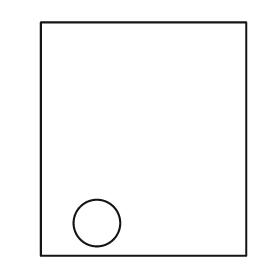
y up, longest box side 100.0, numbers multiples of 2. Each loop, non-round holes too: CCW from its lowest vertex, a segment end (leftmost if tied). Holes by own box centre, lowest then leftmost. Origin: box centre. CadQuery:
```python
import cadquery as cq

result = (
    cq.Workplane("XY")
    .moveTo(-44.0, -50.0)
    .lineTo(44.0, -50.0)
    .lineTo(44.0, 50.0)
    .lineTo(-44.0, 50.0)
    .close()
    .moveTo(-20.0, -36.0)
    .circle(10.0)
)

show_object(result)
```